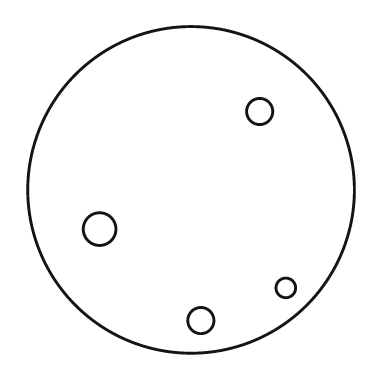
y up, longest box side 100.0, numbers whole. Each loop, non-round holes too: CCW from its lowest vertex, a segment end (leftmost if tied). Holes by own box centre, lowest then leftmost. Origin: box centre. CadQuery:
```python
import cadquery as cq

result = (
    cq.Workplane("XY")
    .moveTo(0.0, 0.0)
    .circle(50.0)
    .moveTo(3.0, -40.0)
    .circle(4.0)
    .moveTo(29.0, -30.0)
    .circle(3.0)
    .moveTo(-28.0, -12.0)
    .circle(5.0)
    .moveTo(21.0, 24.0)
    .circle(4.0)
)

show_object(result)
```